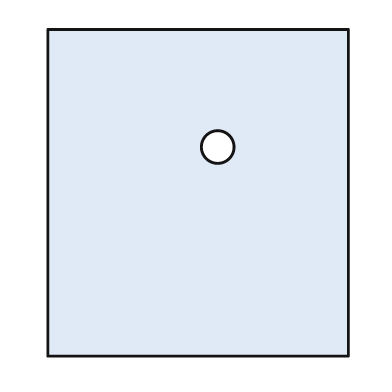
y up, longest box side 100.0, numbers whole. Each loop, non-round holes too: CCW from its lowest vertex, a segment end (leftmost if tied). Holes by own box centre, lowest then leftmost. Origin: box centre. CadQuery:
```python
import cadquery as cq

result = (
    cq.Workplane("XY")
    .moveTo(-46.0, -50.0)
    .lineTo(46.0, -50.0)
    .lineTo(46.0, 50.0)
    .lineTo(-46.0, 50.0)
    .close()
    .moveTo(6.0, 14.0)
    .circle(5.0)
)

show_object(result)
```